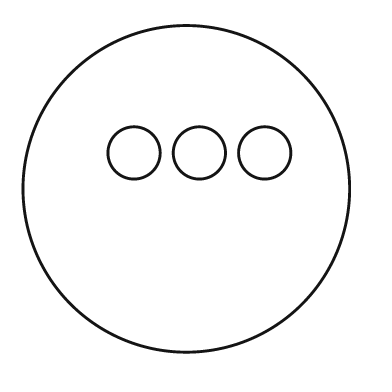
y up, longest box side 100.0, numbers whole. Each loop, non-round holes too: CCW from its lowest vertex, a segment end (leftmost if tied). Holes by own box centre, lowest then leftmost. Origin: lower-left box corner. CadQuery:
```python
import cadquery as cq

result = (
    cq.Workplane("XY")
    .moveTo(50.0, 50.0)
    .circle(50.0)
    .moveTo(34.0, 61.0)
    .circle(8.0)
    .moveTo(54.0, 61.0)
    .circle(8.0)
    .moveTo(74.0, 61.0)
    .circle(8.0)
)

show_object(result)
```